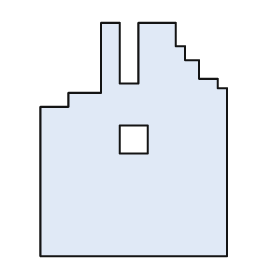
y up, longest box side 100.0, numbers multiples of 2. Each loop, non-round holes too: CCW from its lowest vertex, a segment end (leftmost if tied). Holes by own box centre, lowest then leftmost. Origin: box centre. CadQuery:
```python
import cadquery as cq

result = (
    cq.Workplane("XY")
    .moveTo(-40.0, -50.0)
    .lineTo(40.0, -50.0)
    .lineTo(40.0, 22.0)
    .lineTo(36.0, 22.0)
    .lineTo(36.0, 26.0)
    .lineTo(28.0, 26.0)
    .lineTo(28.0, 34.0)
    .lineTo(22.0, 34.0)
    .lineTo(22.0, 40.0)
    .lineTo(18.0, 40.0)
    .lineTo(18.0, 50.0)
    .lineTo(2.0, 50.0)
    .lineTo(2.0, 24.0)
    .lineTo(-6.0, 24.0)
    .lineTo(-6.0, 50.0)
    .lineTo(-14.0, 50.0)
    .lineTo(-14.0, 20.0)
    .lineTo(-28.0, 20.0)
    .lineTo(-28.0, 14.0)
    .lineTo(-40.0, 14.0)
    .close()
    .moveTo(-6.0, -6.0)
    .lineTo(6.0, -6.0)
    .lineTo(6.0, 6.0)
    .lineTo(-6.0, 6.0)
    .close()
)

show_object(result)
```